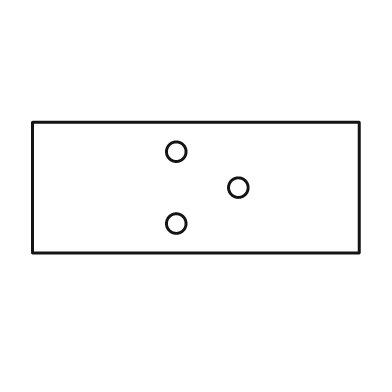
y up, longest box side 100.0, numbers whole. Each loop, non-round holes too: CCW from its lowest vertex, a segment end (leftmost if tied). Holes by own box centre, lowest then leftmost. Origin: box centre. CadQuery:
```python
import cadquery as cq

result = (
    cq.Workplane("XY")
    .moveTo(-50.0, -20.0)
    .lineTo(50.0, -20.0)
    .lineTo(50.0, 20.0)
    .lineTo(-50.0, 20.0)
    .close()
    .moveTo(-6.0, -11.0)
    .circle(3.0)
    .moveTo(13.0, 0.0)
    .circle(3.0)
    .moveTo(-6.0, 11.0)
    .circle(3.0)
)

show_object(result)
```